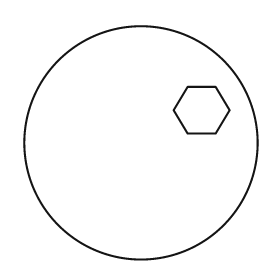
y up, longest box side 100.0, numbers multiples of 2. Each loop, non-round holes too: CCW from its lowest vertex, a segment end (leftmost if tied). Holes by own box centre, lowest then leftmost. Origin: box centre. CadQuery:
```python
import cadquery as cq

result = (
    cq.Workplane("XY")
    .moveTo(0.0, 0.0)
    .circle(50.0)
    .moveTo(20.0, 4.0)
    .lineTo(32.0, 4.0)
    .lineTo(38.0, 14.0)
    .lineTo(32.0, 24.0)
    .lineTo(20.0, 24.0)
    .lineTo(14.0, 14.0)
    .close()
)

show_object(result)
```